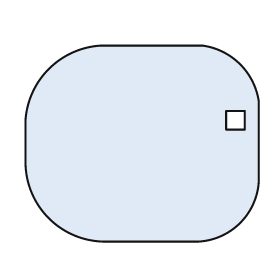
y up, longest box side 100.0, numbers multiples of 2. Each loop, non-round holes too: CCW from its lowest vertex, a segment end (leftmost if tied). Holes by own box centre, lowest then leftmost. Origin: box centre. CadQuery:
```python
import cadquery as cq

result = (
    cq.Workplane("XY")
    .moveTo(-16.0, -42.0)
    .lineTo(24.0, -42.0)
    .threePointArc((42.0, -34.0), (50.0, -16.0))
    .lineTo(50.0, 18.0)
    .threePointArc((42.0, 34.0), (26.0, 42.0))
    .lineTo(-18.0, 42.0)
    .threePointArc((-40.0, 32.0), (-50.0, 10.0))
    .lineTo(-50.0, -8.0)
    .threePointArc((-40.0, -32.0), (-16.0, -42.0))
    .close()
    .moveTo(36.0, 6.0)
    .lineTo(44.0, 6.0)
    .lineTo(44.0, 14.0)
    .lineTo(36.0, 14.0)
    .close()
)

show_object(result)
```